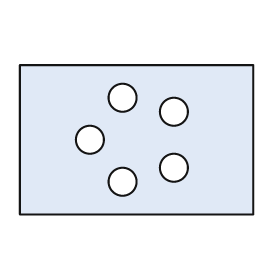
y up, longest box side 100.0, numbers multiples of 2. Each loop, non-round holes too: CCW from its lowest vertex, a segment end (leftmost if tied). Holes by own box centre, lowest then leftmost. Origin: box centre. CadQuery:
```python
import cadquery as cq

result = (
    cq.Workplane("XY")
    .moveTo(-50.0, -32.0)
    .lineTo(50.0, -32.0)
    .lineTo(50.0, 32.0)
    .lineTo(-50.0, 32.0)
    .close()
    .moveTo(-6.0, -18.0)
    .circle(6.0)
    .moveTo(16.0, -12.0)
    .circle(6.0)
    .moveTo(-20.0, 0.0)
    .circle(6.0)
    .moveTo(16.0, 12.0)
    .circle(6.0)
    .moveTo(-6.0, 18.0)
    .circle(6.0)
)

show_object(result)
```